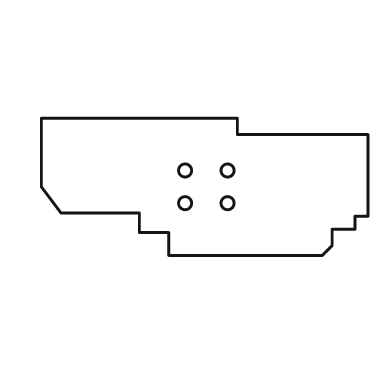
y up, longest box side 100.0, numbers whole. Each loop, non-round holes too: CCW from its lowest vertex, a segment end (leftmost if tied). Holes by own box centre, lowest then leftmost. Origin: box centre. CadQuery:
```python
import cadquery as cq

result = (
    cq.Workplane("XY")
    .moveTo(-11.0, -21.0)
    .lineTo(36.0, -21.0)
    .lineTo(39.0, -18.0)
    .lineTo(39.0, -13.0)
    .lineTo(46.0, -13.0)
    .lineTo(46.0, -9.0)
    .lineTo(50.0, -9.0)
    .lineTo(50.0, 16.0)
    .lineTo(10.0, 16.0)
    .lineTo(10.0, 21.0)
    .lineTo(-50.0, 21.0)
    .lineTo(-50.0, 0.0)
    .lineTo(-44.0, -8.0)
    .lineTo(-20.0, -8.0)
    .lineTo(-20.0, -14.0)
    .lineTo(-11.0, -14.0)
    .close()
    .moveTo(-6.0, -5.0)
    .circle(2.0)
    .moveTo(7.0, -5.0)
    .circle(2.0)
    .moveTo(-6.0, 5.0)
    .circle(2.0)
    .moveTo(7.0, 5.0)
    .circle(2.0)
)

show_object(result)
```